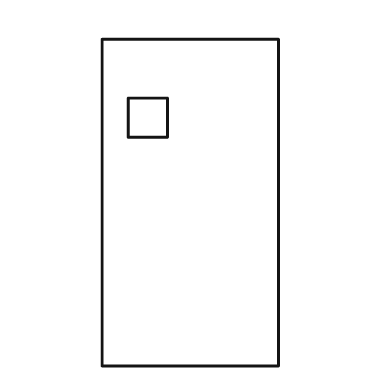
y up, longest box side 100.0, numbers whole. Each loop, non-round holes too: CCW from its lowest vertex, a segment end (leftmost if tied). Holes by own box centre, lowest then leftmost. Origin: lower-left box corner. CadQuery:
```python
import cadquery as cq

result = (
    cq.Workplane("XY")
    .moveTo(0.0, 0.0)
    .lineTo(54.0, 0.0)
    .lineTo(54.0, 100.0)
    .lineTo(0.0, 100.0)
    .close()
    .moveTo(8.0, 70.0)
    .lineTo(20.0, 70.0)
    .lineTo(20.0, 82.0)
    .lineTo(8.0, 82.0)
    .close()
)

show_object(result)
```